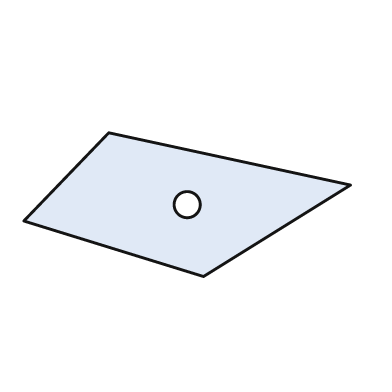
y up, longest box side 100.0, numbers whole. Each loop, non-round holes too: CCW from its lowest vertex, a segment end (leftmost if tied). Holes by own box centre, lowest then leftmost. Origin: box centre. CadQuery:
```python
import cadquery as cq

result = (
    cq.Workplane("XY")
    .moveTo(5.0, -22.0)
    .lineTo(50.0, 6.0)
    .lineTo(-24.0, 22.0)
    .lineTo(-50.0, -5.0)
    .close()
    .moveTo(0.0, 0.0)
    .circle(4.0)
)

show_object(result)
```